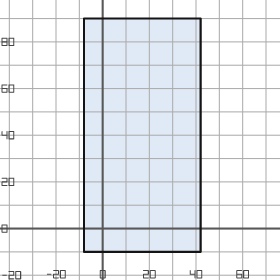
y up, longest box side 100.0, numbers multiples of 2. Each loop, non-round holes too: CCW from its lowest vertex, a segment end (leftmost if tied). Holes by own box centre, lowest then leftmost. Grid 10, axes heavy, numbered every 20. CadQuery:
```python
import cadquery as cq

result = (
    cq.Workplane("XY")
    .moveTo(-8.0, -10.0)
    .lineTo(42.0, -10.0)
    .lineTo(42.0, 90.0)
    .lineTo(-8.0, 90.0)
    .close()
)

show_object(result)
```